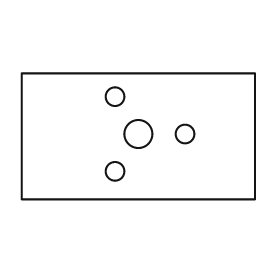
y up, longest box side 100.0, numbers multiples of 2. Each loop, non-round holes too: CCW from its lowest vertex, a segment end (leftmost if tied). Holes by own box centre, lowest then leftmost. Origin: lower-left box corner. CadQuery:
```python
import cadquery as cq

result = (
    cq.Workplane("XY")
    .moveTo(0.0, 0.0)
    .lineTo(100.0, 0.0)
    .lineTo(100.0, 54.0)
    .lineTo(0.0, 54.0)
    .close()
    .moveTo(40.0, 12.0)
    .circle(4.0)
    .moveTo(50.0, 28.0)
    .circle(6.0)
    .moveTo(70.0, 28.0)
    .circle(4.0)
    .moveTo(40.0, 44.0)
    .circle(4.0)
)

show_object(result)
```